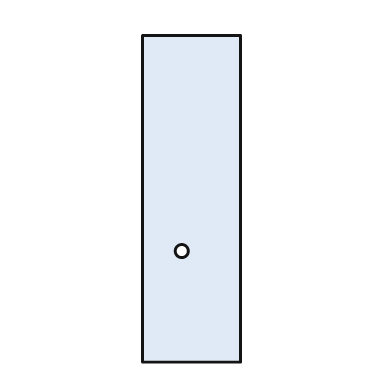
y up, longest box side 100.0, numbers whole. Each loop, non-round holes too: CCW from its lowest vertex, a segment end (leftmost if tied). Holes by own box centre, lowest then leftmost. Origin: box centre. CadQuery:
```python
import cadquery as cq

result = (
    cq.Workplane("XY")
    .moveTo(-15.0, -50.0)
    .lineTo(15.0, -50.0)
    .lineTo(15.0, 50.0)
    .lineTo(-15.0, 50.0)
    .close()
    .moveTo(-3.0, -16.0)
    .circle(2.0)
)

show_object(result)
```